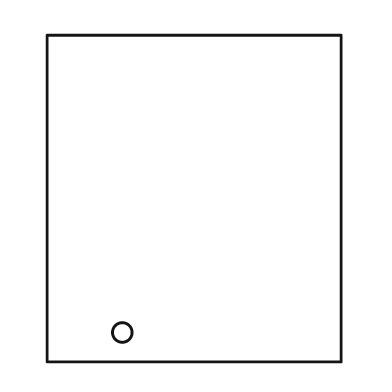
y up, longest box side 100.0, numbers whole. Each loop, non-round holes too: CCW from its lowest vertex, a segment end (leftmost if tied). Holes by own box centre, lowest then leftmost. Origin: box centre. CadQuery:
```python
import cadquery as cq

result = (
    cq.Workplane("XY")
    .moveTo(-45.0, -50.0)
    .lineTo(45.0, -50.0)
    .lineTo(45.0, 50.0)
    .lineTo(-45.0, 50.0)
    .close()
    .moveTo(-22.0, -41.0)
    .circle(3.0)
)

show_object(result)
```